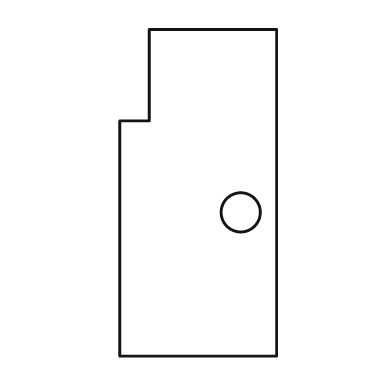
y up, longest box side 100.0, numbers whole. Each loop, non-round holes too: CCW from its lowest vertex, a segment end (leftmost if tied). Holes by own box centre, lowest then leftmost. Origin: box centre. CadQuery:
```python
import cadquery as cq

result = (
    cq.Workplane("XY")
    .moveTo(-24.0, -50.0)
    .lineTo(24.0, -50.0)
    .lineTo(24.0, 50.0)
    .lineTo(-15.0, 50.0)
    .lineTo(-15.0, 22.0)
    .lineTo(-24.0, 22.0)
    .close()
    .moveTo(13.0, -6.0)
    .circle(6.0)
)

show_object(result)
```